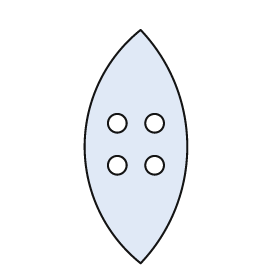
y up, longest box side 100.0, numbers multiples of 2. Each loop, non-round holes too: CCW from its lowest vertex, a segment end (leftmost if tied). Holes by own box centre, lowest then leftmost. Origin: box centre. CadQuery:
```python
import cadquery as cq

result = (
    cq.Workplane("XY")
    .moveTo(2.0, -50.0)
    .threePointArc((22.0, 0.0), (2.0, 50.0))
    .threePointArc((-22.0, 0.0), (2.0, -50.0))
    .close()
    .moveTo(-8.0, -8.0)
    .circle(4.0)
    .moveTo(8.0, -8.0)
    .circle(4.0)
    .moveTo(-8.0, 10.0)
    .circle(4.0)
    .moveTo(8.0, 10.0)
    .circle(4.0)
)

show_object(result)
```